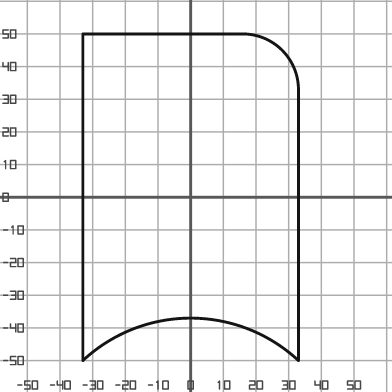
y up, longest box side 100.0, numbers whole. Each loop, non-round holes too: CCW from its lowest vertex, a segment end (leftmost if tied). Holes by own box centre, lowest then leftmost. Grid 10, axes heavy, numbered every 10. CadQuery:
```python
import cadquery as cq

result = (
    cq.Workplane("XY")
    .moveTo(-33.0, -50.0)
    .threePointArc((0.0, -37.0), (33.0, -50.0))
    .lineTo(33.0, 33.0)
    .threePointArc((28.0, 45.0), (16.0, 50.0))
    .lineTo(-33.0, 50.0)
    .close()
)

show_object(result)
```